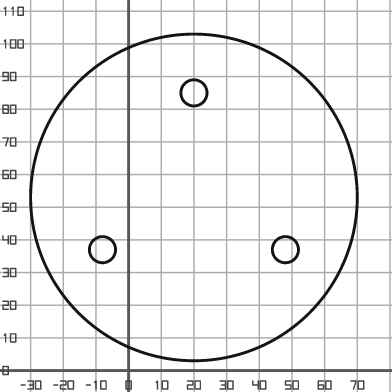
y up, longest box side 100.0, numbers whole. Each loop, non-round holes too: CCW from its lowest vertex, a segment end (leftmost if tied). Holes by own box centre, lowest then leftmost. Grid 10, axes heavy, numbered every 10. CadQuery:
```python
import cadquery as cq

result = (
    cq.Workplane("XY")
    .moveTo(20.0, 53.0)
    .circle(50.0)
    .moveTo(-8.0, 37.0)
    .circle(4.0)
    .moveTo(48.0, 37.0)
    .circle(4.0)
    .moveTo(20.0, 85.0)
    .circle(4.0)
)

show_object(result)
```